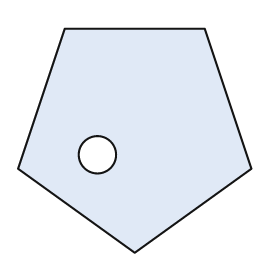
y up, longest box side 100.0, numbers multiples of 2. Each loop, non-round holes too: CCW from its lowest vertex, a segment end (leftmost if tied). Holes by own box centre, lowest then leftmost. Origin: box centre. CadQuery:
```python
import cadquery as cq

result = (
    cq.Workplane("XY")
    .moveTo(0.0, -48.0)
    .lineTo(50.0, -12.0)
    .lineTo(30.0, 48.0)
    .lineTo(-30.0, 48.0)
    .lineTo(-50.0, -12.0)
    .close()
    .moveTo(-16.0, -6.0)
    .circle(8.0)
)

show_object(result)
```